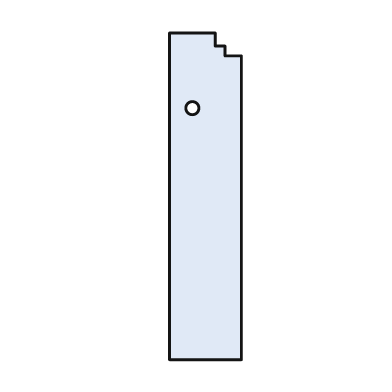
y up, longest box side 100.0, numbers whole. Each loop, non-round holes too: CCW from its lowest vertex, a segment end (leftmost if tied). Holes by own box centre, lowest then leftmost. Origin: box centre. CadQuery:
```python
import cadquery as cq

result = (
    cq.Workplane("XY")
    .moveTo(-11.0, -50.0)
    .lineTo(11.0, -50.0)
    .lineTo(11.0, 43.0)
    .lineTo(6.0, 43.0)
    .lineTo(6.0, 46.0)
    .lineTo(3.0, 46.0)
    .lineTo(3.0, 50.0)
    .lineTo(-11.0, 50.0)
    .close()
    .moveTo(-4.0, 27.0)
    .circle(2.0)
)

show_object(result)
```